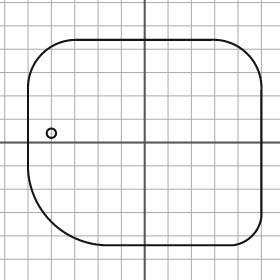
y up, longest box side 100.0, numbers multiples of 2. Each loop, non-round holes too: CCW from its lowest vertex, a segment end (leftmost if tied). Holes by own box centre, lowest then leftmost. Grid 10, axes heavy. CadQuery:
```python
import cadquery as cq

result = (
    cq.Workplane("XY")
    .moveTo(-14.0, -44.0)
    .lineTo(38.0, -44.0)
    .threePointArc((46.0, -40.0), (50.0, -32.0))
    .lineTo(50.0, 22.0)
    .threePointArc((44.0, 38.0), (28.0, 44.0))
    .lineTo(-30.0, 44.0)
    .threePointArc((-44.0, 38.0), (-50.0, 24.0))
    .lineTo(-50.0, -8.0)
    .threePointArc((-40.0, -34.0), (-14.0, -44.0))
    .close()
    .moveTo(-40.0, 4.0)
    .circle(2.0)
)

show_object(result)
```